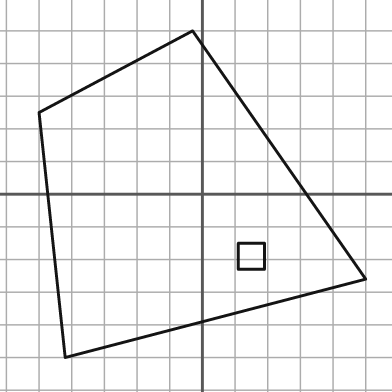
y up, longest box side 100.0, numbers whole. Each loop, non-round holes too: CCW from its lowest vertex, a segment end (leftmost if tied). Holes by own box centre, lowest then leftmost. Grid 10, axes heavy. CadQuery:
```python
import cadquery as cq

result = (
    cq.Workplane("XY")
    .moveTo(-42.0, -50.0)
    .lineTo(50.0, -26.0)
    .lineTo(-3.0, 50.0)
    .lineTo(-50.0, 25.0)
    .close()
    .moveTo(11.0, -23.0)
    .lineTo(19.0, -23.0)
    .lineTo(19.0, -15.0)
    .lineTo(11.0, -15.0)
    .close()
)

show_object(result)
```